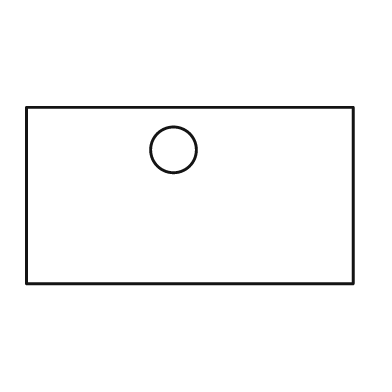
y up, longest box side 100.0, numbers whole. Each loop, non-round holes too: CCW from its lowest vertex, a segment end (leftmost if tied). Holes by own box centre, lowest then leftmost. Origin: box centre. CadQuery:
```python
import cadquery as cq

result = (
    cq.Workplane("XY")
    .moveTo(-50.0, -27.0)
    .lineTo(50.0, -27.0)
    .lineTo(50.0, 27.0)
    .lineTo(-50.0, 27.0)
    .close()
    .moveTo(-5.0, 14.0)
    .circle(7.0)
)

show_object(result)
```